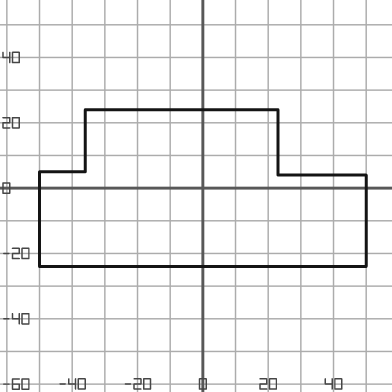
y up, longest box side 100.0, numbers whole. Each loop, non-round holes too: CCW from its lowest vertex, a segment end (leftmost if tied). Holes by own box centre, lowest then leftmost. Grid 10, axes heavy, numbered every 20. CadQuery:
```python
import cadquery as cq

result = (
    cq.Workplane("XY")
    .moveTo(-50.0, -24.0)
    .lineTo(50.0, -24.0)
    .lineTo(50.0, 4.0)
    .lineTo(23.0, 4.0)
    .lineTo(23.0, 24.0)
    .lineTo(-36.0, 24.0)
    .lineTo(-36.0, 5.0)
    .lineTo(-50.0, 5.0)
    .close()
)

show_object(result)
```